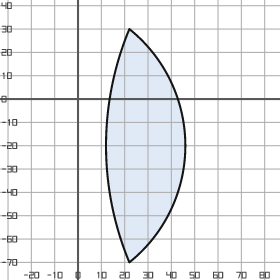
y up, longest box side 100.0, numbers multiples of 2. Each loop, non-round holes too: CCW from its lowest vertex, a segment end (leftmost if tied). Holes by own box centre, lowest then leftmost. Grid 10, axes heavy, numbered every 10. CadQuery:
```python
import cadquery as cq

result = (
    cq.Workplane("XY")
    .moveTo(22.0, -70.0)
    .threePointArc((46.0, -20.0), (22.0, 30.0))
    .threePointArc((12.0, -20.0), (22.0, -70.0))
    .close()
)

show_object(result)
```